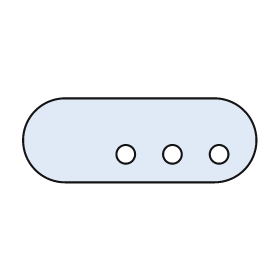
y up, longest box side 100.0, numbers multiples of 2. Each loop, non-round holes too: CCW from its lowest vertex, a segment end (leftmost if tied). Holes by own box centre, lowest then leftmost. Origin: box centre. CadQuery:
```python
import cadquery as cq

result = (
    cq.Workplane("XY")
    .moveTo(-32.0, -18.0)
    .lineTo(32.0, -18.0)
    .threePointArc((50.0, 0.0), (32.0, 18.0))
    .lineTo(-32.0, 18.0)
    .threePointArc((-50.0, 0.0), (-32.0, -18.0))
    .close()
    .moveTo(-6.0, -6.0)
    .circle(4.0)
    .moveTo(14.0, -6.0)
    .circle(4.0)
    .moveTo(34.0, -6.0)
    .circle(4.0)
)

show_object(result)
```